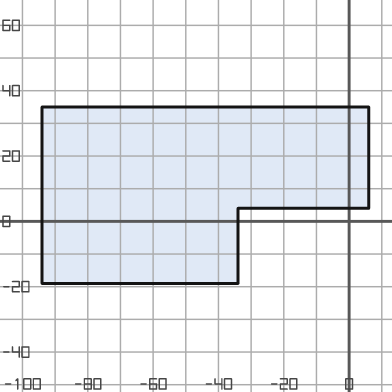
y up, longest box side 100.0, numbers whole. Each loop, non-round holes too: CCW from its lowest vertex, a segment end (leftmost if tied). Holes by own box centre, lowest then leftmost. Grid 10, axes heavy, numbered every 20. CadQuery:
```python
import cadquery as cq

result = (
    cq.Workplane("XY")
    .moveTo(-94.0, -19.0)
    .lineTo(-34.0, -19.0)
    .lineTo(-34.0, 4.0)
    .lineTo(6.0, 4.0)
    .lineTo(6.0, 35.0)
    .lineTo(-94.0, 35.0)
    .close()
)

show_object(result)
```